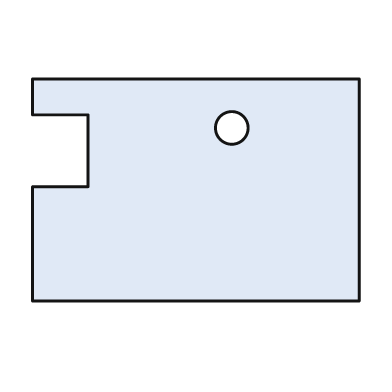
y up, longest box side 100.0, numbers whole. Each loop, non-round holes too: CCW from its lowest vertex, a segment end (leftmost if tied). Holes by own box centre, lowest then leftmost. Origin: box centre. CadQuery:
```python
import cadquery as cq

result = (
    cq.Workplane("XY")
    .moveTo(-50.0, -34.0)
    .lineTo(50.0, -34.0)
    .lineTo(50.0, 34.0)
    .lineTo(-50.0, 34.0)
    .lineTo(-50.0, 23.0)
    .lineTo(-33.0, 23.0)
    .lineTo(-33.0, 1.0)
    .lineTo(-50.0, 1.0)
    .close()
    .moveTo(11.0, 19.0)
    .circle(5.0)
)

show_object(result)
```